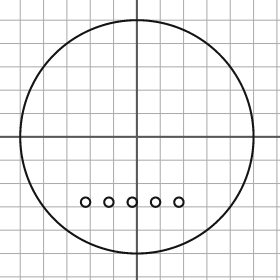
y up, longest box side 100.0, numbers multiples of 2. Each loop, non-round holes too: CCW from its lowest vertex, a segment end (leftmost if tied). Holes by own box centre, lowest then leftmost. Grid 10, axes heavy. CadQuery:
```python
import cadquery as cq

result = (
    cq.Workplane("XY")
    .moveTo(0.0, 0.0)
    .circle(50.0)
    .moveTo(-22.0, -28.0)
    .circle(2.0)
    .moveTo(-12.0, -28.0)
    .circle(2.0)
    .moveTo(-2.0, -28.0)
    .circle(2.0)
    .moveTo(8.0, -28.0)
    .circle(2.0)
    .moveTo(18.0, -28.0)
    .circle(2.0)
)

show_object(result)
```